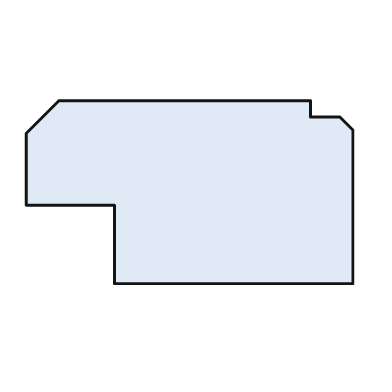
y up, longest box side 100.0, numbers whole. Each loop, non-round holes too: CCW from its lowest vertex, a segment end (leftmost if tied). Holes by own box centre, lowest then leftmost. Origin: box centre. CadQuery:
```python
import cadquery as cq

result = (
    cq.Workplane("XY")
    .moveTo(-23.0, -28.0)
    .lineTo(50.0, -28.0)
    .lineTo(50.0, 19.0)
    .lineTo(46.0, 23.0)
    .lineTo(37.0, 23.0)
    .lineTo(37.0, 28.0)
    .lineTo(-40.0, 28.0)
    .lineTo(-50.0, 18.0)
    .lineTo(-50.0, -4.0)
    .lineTo(-23.0, -4.0)
    .close()
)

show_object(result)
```